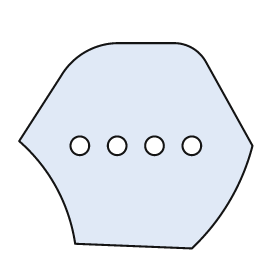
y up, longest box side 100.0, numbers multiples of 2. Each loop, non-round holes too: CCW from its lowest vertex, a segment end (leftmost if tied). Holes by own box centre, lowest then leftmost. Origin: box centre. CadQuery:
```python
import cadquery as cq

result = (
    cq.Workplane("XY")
    .moveTo(24.0, -44.0)
    .threePointArc((40.0, -24.0), (50.0, 0.0))
    .lineTo(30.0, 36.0)
    .threePointArc((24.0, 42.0), (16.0, 44.0))
    .lineTo(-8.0, 44.0)
    .threePointArc((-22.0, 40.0), (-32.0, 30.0))
    .lineTo(-50.0, 2.0)
    .threePointArc((-34.0, -18.0), (-26.0, -42.0))
    .close()
    .moveTo(-24.0, 0.0)
    .circle(4.0)
    .moveTo(-8.0, 0.0)
    .circle(4.0)
    .moveTo(8.0, 0.0)
    .circle(4.0)
    .moveTo(24.0, 0.0)
    .circle(4.0)
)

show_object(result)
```